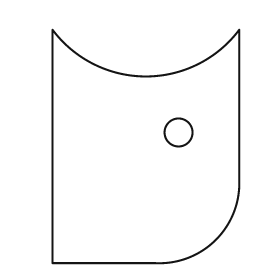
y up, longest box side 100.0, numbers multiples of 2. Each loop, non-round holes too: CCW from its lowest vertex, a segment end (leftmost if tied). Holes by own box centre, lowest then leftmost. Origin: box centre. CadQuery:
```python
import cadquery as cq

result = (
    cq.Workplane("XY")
    .moveTo(-40.0, -50.0)
    .lineTo(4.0, -50.0)
    .threePointArc((30.0, -40.0), (40.0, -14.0))
    .lineTo(40.0, 50.0)
    .threePointArc((0.0, 30.0), (-40.0, 50.0))
    .close()
    .moveTo(14.0, 6.0)
    .circle(6.0)
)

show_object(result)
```